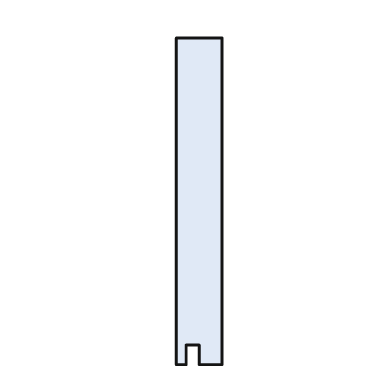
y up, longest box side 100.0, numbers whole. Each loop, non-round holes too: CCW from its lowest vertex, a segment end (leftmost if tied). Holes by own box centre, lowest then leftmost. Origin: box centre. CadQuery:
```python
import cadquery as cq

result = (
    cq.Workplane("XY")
    .moveTo(-7.0, -50.0)
    .lineTo(-4.0, -50.0)
    .lineTo(-4.0, -44.0)
    .lineTo(0.0, -44.0)
    .lineTo(0.0, -50.0)
    .lineTo(7.0, -50.0)
    .lineTo(7.0, 50.0)
    .lineTo(-7.0, 50.0)
    .close()
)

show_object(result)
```